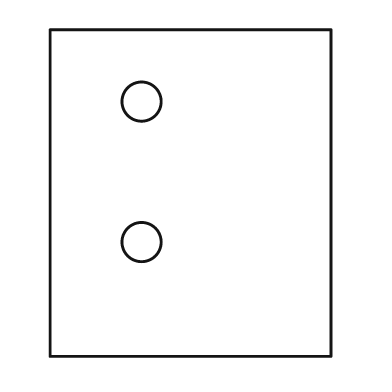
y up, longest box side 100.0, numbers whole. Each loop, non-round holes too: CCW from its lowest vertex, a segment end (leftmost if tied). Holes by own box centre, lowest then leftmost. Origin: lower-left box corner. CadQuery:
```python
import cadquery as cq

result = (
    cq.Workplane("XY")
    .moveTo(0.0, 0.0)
    .lineTo(86.0, 0.0)
    .lineTo(86.0, 100.0)
    .lineTo(0.0, 100.0)
    .close()
    .moveTo(28.0, 35.0)
    .circle(6.0)
    .moveTo(28.0, 78.0)
    .circle(6.0)
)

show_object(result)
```